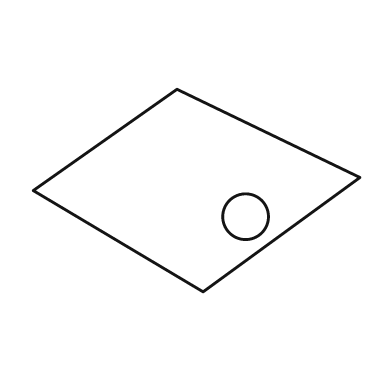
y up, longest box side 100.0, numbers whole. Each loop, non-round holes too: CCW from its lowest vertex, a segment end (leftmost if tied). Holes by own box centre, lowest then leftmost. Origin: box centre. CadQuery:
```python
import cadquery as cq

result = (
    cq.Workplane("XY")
    .moveTo(2.0, -31.0)
    .lineTo(50.0, 4.0)
    .lineTo(-6.0, 31.0)
    .lineTo(-50.0, 0.0)
    .close()
    .moveTo(15.0, -8.0)
    .circle(7.0)
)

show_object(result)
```